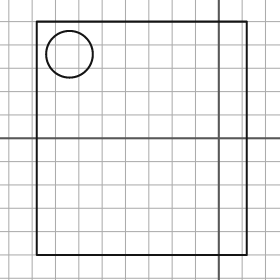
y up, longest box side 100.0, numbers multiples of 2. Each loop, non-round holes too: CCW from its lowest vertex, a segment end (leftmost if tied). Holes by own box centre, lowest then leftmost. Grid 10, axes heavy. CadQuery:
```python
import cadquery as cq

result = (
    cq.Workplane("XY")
    .moveTo(-78.0, -50.0)
    .lineTo(12.0, -50.0)
    .lineTo(12.0, 50.0)
    .lineTo(-78.0, 50.0)
    .close()
    .moveTo(-64.0, 36.0)
    .circle(10.0)
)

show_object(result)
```